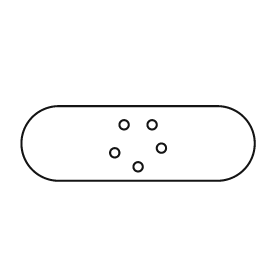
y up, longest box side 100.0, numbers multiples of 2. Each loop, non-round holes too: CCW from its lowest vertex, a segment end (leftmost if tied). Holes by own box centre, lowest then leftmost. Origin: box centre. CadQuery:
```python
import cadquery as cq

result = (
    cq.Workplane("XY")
    .moveTo(-34.0, -16.0)
    .lineTo(34.0, -16.0)
    .threePointArc((50.0, 0.0), (34.0, 16.0))
    .lineTo(-34.0, 16.0)
    .threePointArc((-50.0, 0.0), (-34.0, -16.0))
    .close()
    .moveTo(0.0, -10.0)
    .circle(2.0)
    .moveTo(-10.0, -4.0)
    .circle(2.0)
    .moveTo(10.0, -2.0)
    .circle(2.0)
    .moveTo(-6.0, 8.0)
    .circle(2.0)
    .moveTo(6.0, 8.0)
    .circle(2.0)
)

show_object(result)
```